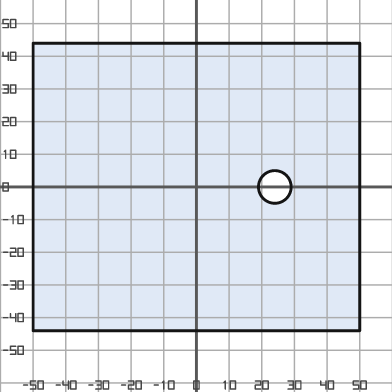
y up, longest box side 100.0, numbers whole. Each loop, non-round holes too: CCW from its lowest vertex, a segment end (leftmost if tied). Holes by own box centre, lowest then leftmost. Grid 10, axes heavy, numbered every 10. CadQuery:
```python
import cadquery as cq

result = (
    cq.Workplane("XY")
    .moveTo(-50.0, -44.0)
    .lineTo(50.0, -44.0)
    .lineTo(50.0, 44.0)
    .lineTo(-50.0, 44.0)
    .close()
    .moveTo(24.0, 0.0)
    .circle(5.0)
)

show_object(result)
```